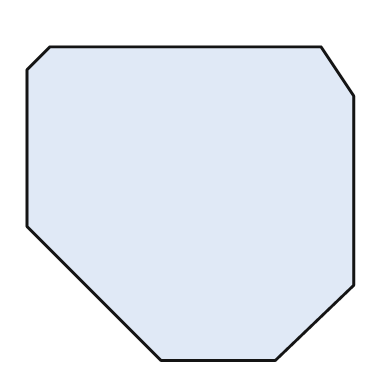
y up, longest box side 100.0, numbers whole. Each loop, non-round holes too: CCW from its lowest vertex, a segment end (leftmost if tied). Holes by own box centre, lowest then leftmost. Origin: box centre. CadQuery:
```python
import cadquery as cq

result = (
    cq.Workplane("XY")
    .moveTo(-9.0, -48.0)
    .lineTo(26.0, -48.0)
    .lineTo(50.0, -25.0)
    .lineTo(50.0, 33.0)
    .lineTo(40.0, 48.0)
    .lineTo(-43.0, 48.0)
    .lineTo(-50.0, 41.0)
    .lineTo(-50.0, -7.0)
    .close()
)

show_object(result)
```